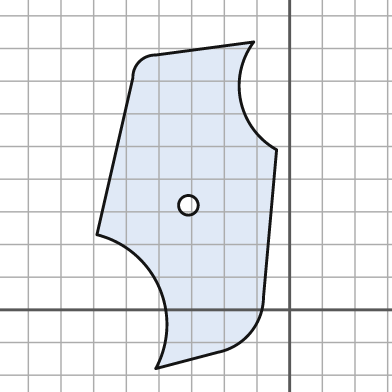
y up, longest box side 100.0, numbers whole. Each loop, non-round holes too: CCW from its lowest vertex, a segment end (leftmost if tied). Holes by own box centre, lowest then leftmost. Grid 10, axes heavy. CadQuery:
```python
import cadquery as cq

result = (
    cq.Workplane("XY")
    .moveTo(-41.0, -18.0)
    .lineTo(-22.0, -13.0)
    .threePointArc((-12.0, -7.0), (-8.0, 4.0))
    .lineTo(-4.0, 49.0)
    .threePointArc((-15.0, 64.0), (-11.0, 82.0))
    .lineTo(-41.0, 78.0)
    .threePointArc((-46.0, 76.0), (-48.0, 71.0))
    .lineTo(-59.0, 23.0)
    .threePointArc((-40.0, 7.0), (-41.0, -18.0))
    .close()
    .moveTo(-31.0, 32.0)
    .circle(3.0)
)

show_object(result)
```